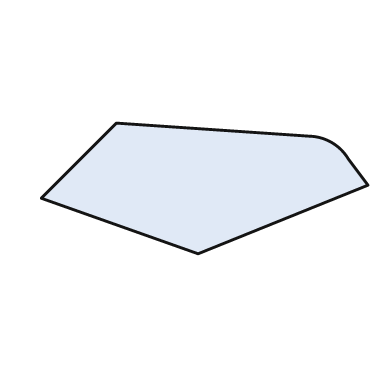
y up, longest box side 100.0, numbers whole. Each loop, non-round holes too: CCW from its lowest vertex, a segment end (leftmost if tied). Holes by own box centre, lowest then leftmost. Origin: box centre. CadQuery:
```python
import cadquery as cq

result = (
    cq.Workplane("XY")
    .moveTo(-2.0, -20.0)
    .lineTo(50.0, 1.0)
    .lineTo(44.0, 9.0)
    .threePointArc((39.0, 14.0), (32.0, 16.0))
    .lineTo(-27.0, 20.0)
    .lineTo(-50.0, -3.0)
    .close()
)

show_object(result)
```